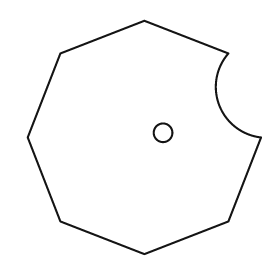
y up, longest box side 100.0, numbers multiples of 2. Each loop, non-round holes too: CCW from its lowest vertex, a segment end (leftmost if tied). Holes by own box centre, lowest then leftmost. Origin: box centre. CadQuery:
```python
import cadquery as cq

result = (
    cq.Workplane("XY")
    .moveTo(0.0, -50.0)
    .lineTo(36.0, -36.0)
    .lineTo(50.0, 0.0)
    .threePointArc((32.0, 14.0), (36.0, 36.0))
    .lineTo(0.0, 50.0)
    .lineTo(-36.0, 36.0)
    .lineTo(-50.0, 0.0)
    .lineTo(-36.0, -36.0)
    .close()
    .moveTo(8.0, 2.0)
    .circle(4.0)
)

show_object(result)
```